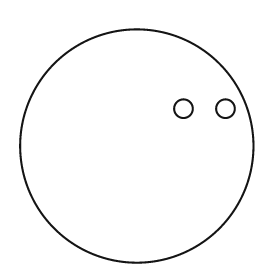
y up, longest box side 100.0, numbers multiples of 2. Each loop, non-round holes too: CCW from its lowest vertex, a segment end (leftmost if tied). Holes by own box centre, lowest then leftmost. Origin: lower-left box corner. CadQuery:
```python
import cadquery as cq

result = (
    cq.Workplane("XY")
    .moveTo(50.0, 50.0)
    .circle(50.0)
    .moveTo(70.0, 66.0)
    .circle(4.0)
    .moveTo(88.0, 66.0)
    .circle(4.0)
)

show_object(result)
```